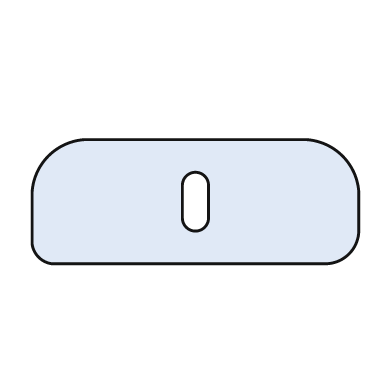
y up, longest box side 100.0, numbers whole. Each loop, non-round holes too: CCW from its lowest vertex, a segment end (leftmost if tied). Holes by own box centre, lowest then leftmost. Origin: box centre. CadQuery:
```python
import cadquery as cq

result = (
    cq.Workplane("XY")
    .moveTo(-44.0, -19.0)
    .lineTo(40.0, -19.0)
    .threePointArc((47.0, -16.0), (50.0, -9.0))
    .lineTo(50.0, 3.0)
    .threePointArc((45.0, 14.0), (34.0, 19.0))
    .lineTo(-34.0, 19.0)
    .threePointArc((-45.0, 14.0), (-50.0, 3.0))
    .lineTo(-50.0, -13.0)
    .threePointArc((-48.0, -17.0), (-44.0, -19.0))
    .close()
    .moveTo(-4.0, -5.0)
    .threePointArc((0.0, -9.0), (4.0, -5.0))
    .lineTo(4.0, 5.0)
    .threePointArc((0.0, 9.0), (-4.0, 5.0))
    .close()
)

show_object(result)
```